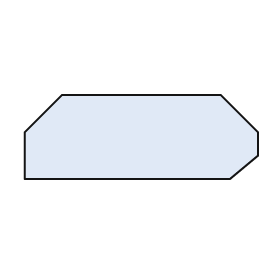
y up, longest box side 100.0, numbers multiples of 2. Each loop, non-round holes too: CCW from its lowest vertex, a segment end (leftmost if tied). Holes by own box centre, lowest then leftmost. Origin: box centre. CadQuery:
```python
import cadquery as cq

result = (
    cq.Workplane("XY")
    .moveTo(-50.0, -18.0)
    .lineTo(38.0, -18.0)
    .lineTo(50.0, -8.0)
    .lineTo(50.0, 2.0)
    .lineTo(34.0, 18.0)
    .lineTo(-34.0, 18.0)
    .lineTo(-50.0, 2.0)
    .close()
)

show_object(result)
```